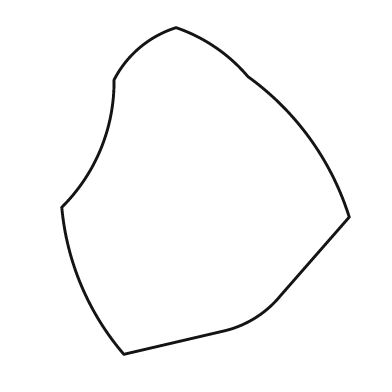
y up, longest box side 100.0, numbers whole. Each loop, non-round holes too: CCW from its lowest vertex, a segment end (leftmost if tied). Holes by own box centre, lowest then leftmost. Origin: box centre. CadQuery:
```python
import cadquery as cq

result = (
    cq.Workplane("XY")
    .moveTo(-25.0, -50.0)
    .lineTo(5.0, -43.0)
    .threePointArc((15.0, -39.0), (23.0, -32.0))
    .lineTo(44.0, -8.0)
    .threePointArc((32.0, 16.0), (13.0, 35.0))
    .threePointArc((3.0, 44.0), (-9.0, 50.0))
    .threePointArc((-20.0, 44.0), (-28.0, 34.0))
    .threePointArc((-32.0, 13.0), (-44.0, -5.0))
    .threePointArc((-38.0, -29.0), (-25.0, -50.0))
    .close()
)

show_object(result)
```